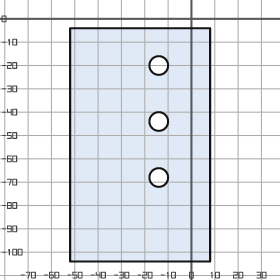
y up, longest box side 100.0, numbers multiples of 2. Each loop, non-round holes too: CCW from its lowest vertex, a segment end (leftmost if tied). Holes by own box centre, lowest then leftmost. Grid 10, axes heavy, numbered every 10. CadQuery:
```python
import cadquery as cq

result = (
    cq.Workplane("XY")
    .moveTo(-52.0, -104.0)
    .lineTo(8.0, -104.0)
    .lineTo(8.0, -4.0)
    .lineTo(-52.0, -4.0)
    .close()
    .moveTo(-14.0, -68.0)
    .circle(4.0)
    .moveTo(-14.0, -44.0)
    .circle(4.0)
    .moveTo(-14.0, -20.0)
    .circle(4.0)
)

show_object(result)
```